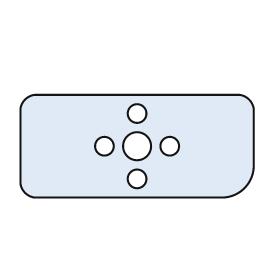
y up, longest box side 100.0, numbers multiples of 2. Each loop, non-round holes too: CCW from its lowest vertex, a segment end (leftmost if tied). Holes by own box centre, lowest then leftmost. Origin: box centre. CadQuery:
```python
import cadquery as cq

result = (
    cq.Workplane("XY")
    .moveTo(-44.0, -22.0)
    .lineTo(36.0, -22.0)
    .threePointArc((46.0, -18.0), (50.0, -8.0))
    .lineTo(50.0, 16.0)
    .threePointArc((48.0, 20.0), (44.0, 22.0))
    .lineTo(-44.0, 22.0)
    .threePointArc((-48.0, 20.0), (-50.0, 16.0))
    .lineTo(-50.0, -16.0)
    .threePointArc((-48.0, -20.0), (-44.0, -22.0))
    .close()
    .moveTo(0.0, -14.0)
    .circle(4.0)
    .moveTo(-14.0, 0.0)
    .circle(4.0)
    .moveTo(0.0, 0.0)
    .circle(6.0)
    .moveTo(14.0, 0.0)
    .circle(4.0)
    .moveTo(0.0, 14.0)
    .circle(4.0)
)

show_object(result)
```